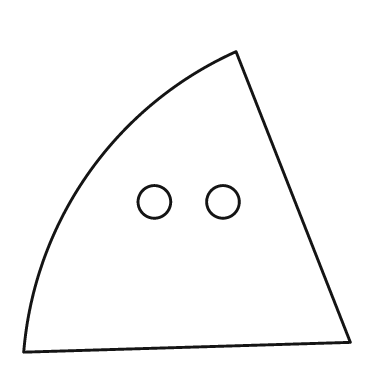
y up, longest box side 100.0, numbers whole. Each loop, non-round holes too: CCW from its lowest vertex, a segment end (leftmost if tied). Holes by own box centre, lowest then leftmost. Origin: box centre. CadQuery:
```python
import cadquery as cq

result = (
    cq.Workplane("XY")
    .moveTo(-50.0, -46.0)
    .lineTo(50.0, -43.0)
    .lineTo(15.0, 46.0)
    .threePointArc((-30.0, 9.0), (-50.0, -46.0))
    .close()
    .moveTo(-10.0, 0.0)
    .circle(5.0)
    .moveTo(11.0, 0.0)
    .circle(5.0)
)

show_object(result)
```